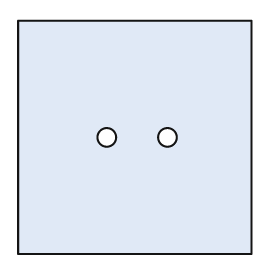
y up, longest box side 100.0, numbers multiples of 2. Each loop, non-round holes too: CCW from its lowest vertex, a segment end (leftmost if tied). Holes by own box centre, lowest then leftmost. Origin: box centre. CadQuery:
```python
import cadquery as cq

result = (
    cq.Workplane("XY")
    .moveTo(-50.0, -50.0)
    .lineTo(50.0, -50.0)
    .lineTo(50.0, 50.0)
    .lineTo(-50.0, 50.0)
    .close()
    .moveTo(-12.0, 0.0)
    .circle(4.0)
    .moveTo(14.0, 0.0)
    .circle(4.0)
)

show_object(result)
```